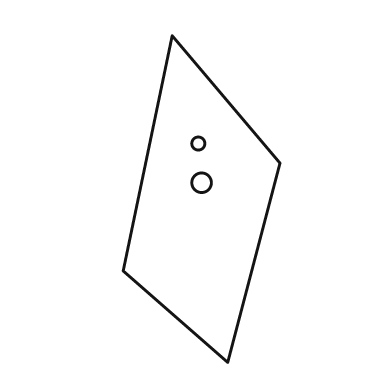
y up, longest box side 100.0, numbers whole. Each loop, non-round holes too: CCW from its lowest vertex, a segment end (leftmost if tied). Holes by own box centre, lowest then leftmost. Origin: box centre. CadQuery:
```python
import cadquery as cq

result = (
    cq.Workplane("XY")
    .moveTo(8.0, -50.0)
    .lineTo(24.0, 11.0)
    .lineTo(-9.0, 50.0)
    .lineTo(-24.0, -22.0)
    .close()
    .moveTo(0.0, 5.0)
    .circle(3.0)
    .moveTo(-1.0, 17.0)
    .circle(2.0)
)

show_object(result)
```